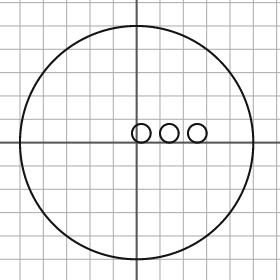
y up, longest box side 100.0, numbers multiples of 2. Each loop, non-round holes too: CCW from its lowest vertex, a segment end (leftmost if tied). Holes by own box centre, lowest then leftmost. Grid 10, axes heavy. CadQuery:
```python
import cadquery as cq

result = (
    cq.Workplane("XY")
    .moveTo(0.0, 0.0)
    .circle(50.0)
    .moveTo(2.0, 4.0)
    .circle(4.0)
    .moveTo(14.0, 4.0)
    .circle(4.0)
    .moveTo(26.0, 4.0)
    .circle(4.0)
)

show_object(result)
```